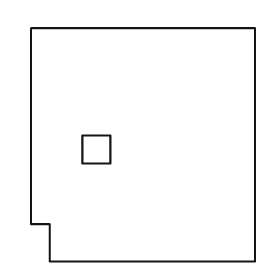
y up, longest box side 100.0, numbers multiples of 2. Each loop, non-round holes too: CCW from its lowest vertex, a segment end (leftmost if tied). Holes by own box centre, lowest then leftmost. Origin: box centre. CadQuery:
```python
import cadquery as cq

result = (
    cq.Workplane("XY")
    .moveTo(-40.0, -50.0)
    .lineTo(48.0, -50.0)
    .lineTo(48.0, 50.0)
    .lineTo(-48.0, 50.0)
    .lineTo(-48.0, -34.0)
    .lineTo(-40.0, -34.0)
    .close()
    .moveTo(-26.0, -8.0)
    .lineTo(-14.0, -8.0)
    .lineTo(-14.0, 4.0)
    .lineTo(-26.0, 4.0)
    .close()
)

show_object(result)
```